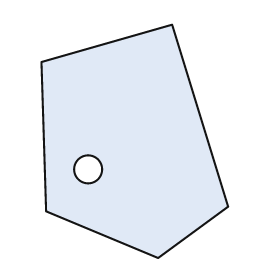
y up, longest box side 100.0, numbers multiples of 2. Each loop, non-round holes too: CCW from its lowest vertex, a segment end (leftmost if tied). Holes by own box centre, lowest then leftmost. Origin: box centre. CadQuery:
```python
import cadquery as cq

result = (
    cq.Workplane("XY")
    .moveTo(10.0, -50.0)
    .lineTo(40.0, -28.0)
    .lineTo(16.0, 50.0)
    .lineTo(-40.0, 34.0)
    .lineTo(-38.0, -30.0)
    .close()
    .moveTo(-20.0, -12.0)
    .circle(6.0)
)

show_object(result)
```